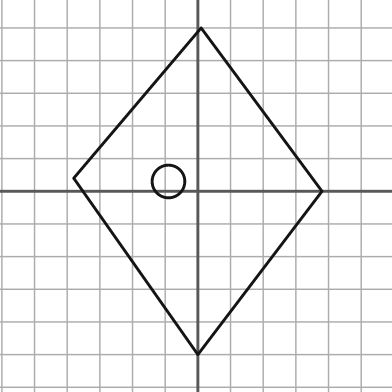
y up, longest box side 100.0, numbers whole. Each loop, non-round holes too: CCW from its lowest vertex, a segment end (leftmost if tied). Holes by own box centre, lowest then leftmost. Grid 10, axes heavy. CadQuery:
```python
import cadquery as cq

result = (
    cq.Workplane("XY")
    .moveTo(0.0, -50.0)
    .lineTo(38.0, 0.0)
    .lineTo(1.0, 50.0)
    .lineTo(-38.0, 4.0)
    .close()
    .moveTo(-9.0, 3.0)
    .circle(5.0)
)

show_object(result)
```